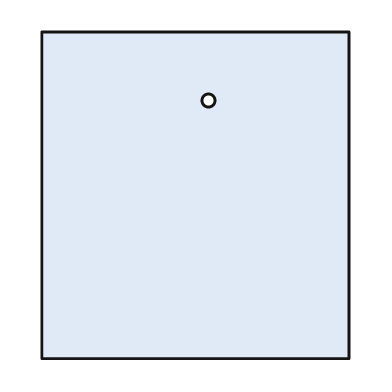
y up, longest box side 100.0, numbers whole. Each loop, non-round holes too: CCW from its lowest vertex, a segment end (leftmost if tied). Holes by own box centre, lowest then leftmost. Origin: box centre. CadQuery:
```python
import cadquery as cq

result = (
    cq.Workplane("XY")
    .moveTo(-47.0, -50.0)
    .lineTo(47.0, -50.0)
    .lineTo(47.0, 50.0)
    .lineTo(-47.0, 50.0)
    .close()
    .moveTo(4.0, 29.0)
    .circle(2.0)
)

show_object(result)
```